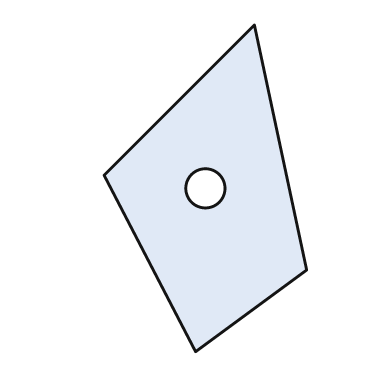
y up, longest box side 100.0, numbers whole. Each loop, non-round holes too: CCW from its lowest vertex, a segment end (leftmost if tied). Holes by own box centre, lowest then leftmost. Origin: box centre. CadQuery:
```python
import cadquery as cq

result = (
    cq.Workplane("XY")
    .moveTo(-3.0, -50.0)
    .lineTo(31.0, -25.0)
    .lineTo(15.0, 50.0)
    .lineTo(-31.0, 4.0)
    .close()
    .moveTo(0.0, 0.0)
    .circle(6.0)
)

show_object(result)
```